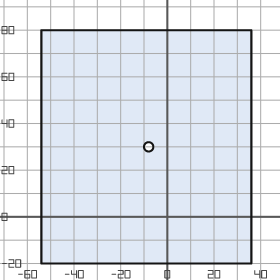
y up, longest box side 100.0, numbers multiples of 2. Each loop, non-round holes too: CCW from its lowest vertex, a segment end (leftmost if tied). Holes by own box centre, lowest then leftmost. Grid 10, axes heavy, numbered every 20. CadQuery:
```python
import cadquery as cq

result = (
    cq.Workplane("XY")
    .moveTo(-54.0, -20.0)
    .lineTo(36.0, -20.0)
    .lineTo(36.0, 80.0)
    .lineTo(-54.0, 80.0)
    .close()
    .moveTo(-8.0, 30.0)
    .circle(2.0)
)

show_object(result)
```